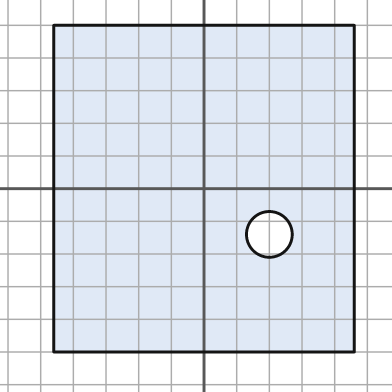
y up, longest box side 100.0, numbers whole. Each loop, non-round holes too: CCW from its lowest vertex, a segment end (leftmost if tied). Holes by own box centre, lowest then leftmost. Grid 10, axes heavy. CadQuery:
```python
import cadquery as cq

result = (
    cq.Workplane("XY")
    .moveTo(-46.0, -50.0)
    .lineTo(46.0, -50.0)
    .lineTo(46.0, 50.0)
    .lineTo(-46.0, 50.0)
    .close()
    .moveTo(20.0, -14.0)
    .circle(7.0)
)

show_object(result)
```